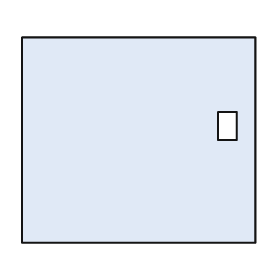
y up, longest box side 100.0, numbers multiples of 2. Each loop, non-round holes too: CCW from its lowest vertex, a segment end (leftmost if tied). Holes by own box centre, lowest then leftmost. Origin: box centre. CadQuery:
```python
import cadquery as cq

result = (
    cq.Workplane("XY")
    .moveTo(-50.0, -44.0)
    .lineTo(50.0, -44.0)
    .lineTo(50.0, 44.0)
    .lineTo(-50.0, 44.0)
    .close()
    .moveTo(34.0, 0.0)
    .lineTo(42.0, 0.0)
    .lineTo(42.0, 12.0)
    .lineTo(34.0, 12.0)
    .close()
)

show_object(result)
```